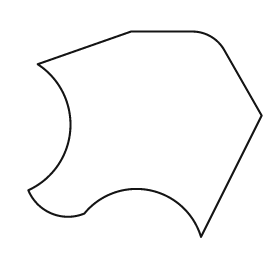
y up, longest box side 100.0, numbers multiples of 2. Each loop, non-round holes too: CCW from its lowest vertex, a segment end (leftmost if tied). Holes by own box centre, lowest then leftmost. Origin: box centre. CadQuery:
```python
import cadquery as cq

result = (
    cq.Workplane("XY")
    .moveTo(24.0, -44.0)
    .lineTo(50.0, 8.0)
    .lineTo(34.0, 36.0)
    .threePointArc((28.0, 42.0), (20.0, 44.0))
    .lineTo(-6.0, 44.0)
    .lineTo(-46.0, 30.0)
    .threePointArc((-32.0, 2.0), (-50.0, -24.0))
    .threePointArc((-40.0, -34.0), (-26.0, -34.0))
    .threePointArc((2.0, -24.0), (24.0, -44.0))
    .close()
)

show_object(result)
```